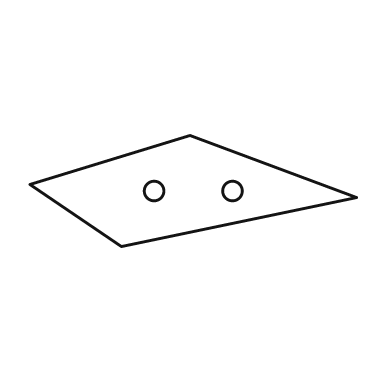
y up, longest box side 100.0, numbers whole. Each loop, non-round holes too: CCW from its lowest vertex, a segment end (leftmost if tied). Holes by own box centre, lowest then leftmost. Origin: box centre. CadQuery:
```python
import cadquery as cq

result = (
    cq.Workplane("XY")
    .moveTo(-22.0, -17.0)
    .lineTo(50.0, -2.0)
    .lineTo(-1.0, 17.0)
    .lineTo(-50.0, 2.0)
    .close()
    .moveTo(-12.0, 0.0)
    .circle(3.0)
    .moveTo(12.0, 0.0)
    .circle(3.0)
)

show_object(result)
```